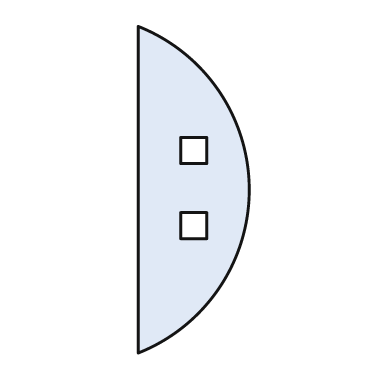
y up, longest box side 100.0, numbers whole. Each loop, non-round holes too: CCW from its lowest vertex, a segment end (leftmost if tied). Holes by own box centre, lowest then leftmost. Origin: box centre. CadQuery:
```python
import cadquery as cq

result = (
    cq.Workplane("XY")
    .moveTo(-17.0, -50.0)
    .threePointArc((17.0, 0.0), (-17.0, 50.0))
    .close()
    .moveTo(-4.0, -15.0)
    .lineTo(4.0, -15.0)
    .lineTo(4.0, -7.0)
    .lineTo(-4.0, -7.0)
    .close()
    .moveTo(-4.0, 8.0)
    .lineTo(4.0, 8.0)
    .lineTo(4.0, 16.0)
    .lineTo(-4.0, 16.0)
    .close()
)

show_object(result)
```